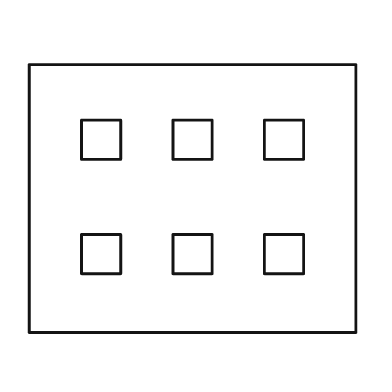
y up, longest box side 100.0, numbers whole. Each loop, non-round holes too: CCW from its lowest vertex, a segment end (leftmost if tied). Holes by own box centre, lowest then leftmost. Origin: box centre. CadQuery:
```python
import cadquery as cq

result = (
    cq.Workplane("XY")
    .moveTo(-50.0, -41.0)
    .lineTo(50.0, -41.0)
    .lineTo(50.0, 41.0)
    .lineTo(-50.0, 41.0)
    .close()
    .moveTo(-34.0, -23.0)
    .lineTo(-22.0, -23.0)
    .lineTo(-22.0, -11.0)
    .lineTo(-34.0, -11.0)
    .close()
    .moveTo(-6.0, -23.0)
    .lineTo(6.0, -23.0)
    .lineTo(6.0, -11.0)
    .lineTo(-6.0, -11.0)
    .close()
    .moveTo(22.0, -23.0)
    .lineTo(34.0, -23.0)
    .lineTo(34.0, -11.0)
    .lineTo(22.0, -11.0)
    .close()
    .moveTo(-34.0, 12.0)
    .lineTo(-22.0, 12.0)
    .lineTo(-22.0, 24.0)
    .lineTo(-34.0, 24.0)
    .close()
    .moveTo(-6.0, 12.0)
    .lineTo(6.0, 12.0)
    .lineTo(6.0, 24.0)
    .lineTo(-6.0, 24.0)
    .close()
    .moveTo(22.0, 12.0)
    .lineTo(34.0, 12.0)
    .lineTo(34.0, 24.0)
    .lineTo(22.0, 24.0)
    .close()
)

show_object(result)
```